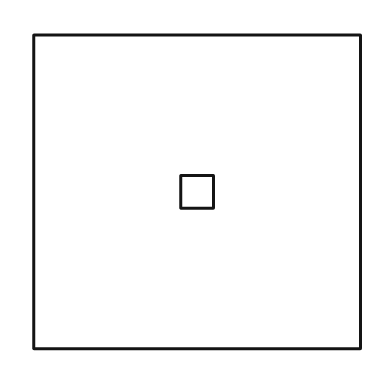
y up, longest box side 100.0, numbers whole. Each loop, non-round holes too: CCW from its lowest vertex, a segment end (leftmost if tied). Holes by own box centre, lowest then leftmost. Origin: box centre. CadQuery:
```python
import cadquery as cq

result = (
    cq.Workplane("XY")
    .moveTo(-50.0, -48.0)
    .lineTo(50.0, -48.0)
    .lineTo(50.0, 48.0)
    .lineTo(-50.0, 48.0)
    .close()
    .moveTo(-5.0, -5.0)
    .lineTo(5.0, -5.0)
    .lineTo(5.0, 5.0)
    .lineTo(-5.0, 5.0)
    .close()
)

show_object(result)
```